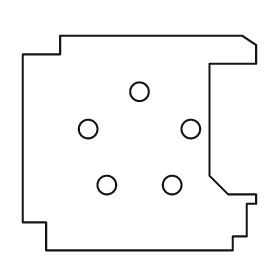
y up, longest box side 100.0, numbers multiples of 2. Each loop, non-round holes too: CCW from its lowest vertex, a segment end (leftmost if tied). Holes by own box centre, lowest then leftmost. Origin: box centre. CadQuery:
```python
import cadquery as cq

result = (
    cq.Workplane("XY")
    .moveTo(-40.0, -46.0)
    .lineTo(40.0, -46.0)
    .lineTo(40.0, -40.0)
    .lineTo(46.0, -40.0)
    .lineTo(46.0, -26.0)
    .lineTo(50.0, -26.0)
    .lineTo(50.0, -22.0)
    .lineTo(38.0, -22.0)
    .lineTo(30.0, -14.0)
    .lineTo(30.0, 34.0)
    .lineTo(50.0, 34.0)
    .lineTo(50.0, 42.0)
    .lineTo(44.0, 46.0)
    .lineTo(-34.0, 46.0)
    .lineTo(-34.0, 38.0)
    .lineTo(-50.0, 38.0)
    .lineTo(-50.0, -34.0)
    .lineTo(-40.0, -34.0)
    .close()
    .moveTo(-14.0, -18.0)
    .circle(4.0)
    .moveTo(14.0, -18.0)
    .circle(4.0)
    .moveTo(-22.0, 6.0)
    .circle(4.0)
    .moveTo(22.0, 6.0)
    .circle(4.0)
    .moveTo(0.0, 22.0)
    .circle(4.0)
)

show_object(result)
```